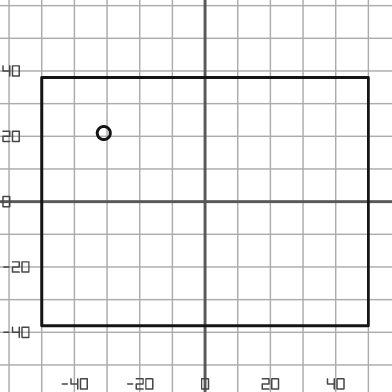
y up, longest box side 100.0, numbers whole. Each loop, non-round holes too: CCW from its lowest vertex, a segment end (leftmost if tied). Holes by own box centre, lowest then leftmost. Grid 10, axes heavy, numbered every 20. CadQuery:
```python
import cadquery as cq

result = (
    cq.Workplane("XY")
    .moveTo(-50.0, -38.0)
    .lineTo(50.0, -38.0)
    .lineTo(50.0, 38.0)
    .lineTo(-50.0, 38.0)
    .close()
    .moveTo(-31.0, 21.0)
    .circle(2.0)
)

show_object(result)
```